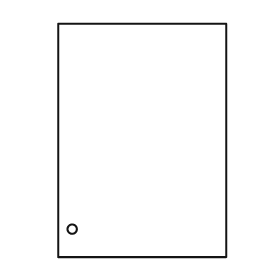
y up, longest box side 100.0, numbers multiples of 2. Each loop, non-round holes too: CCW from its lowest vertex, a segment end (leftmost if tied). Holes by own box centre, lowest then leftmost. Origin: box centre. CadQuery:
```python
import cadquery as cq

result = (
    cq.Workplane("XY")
    .moveTo(-36.0, -50.0)
    .lineTo(36.0, -50.0)
    .lineTo(36.0, 50.0)
    .lineTo(-36.0, 50.0)
    .close()
    .moveTo(-30.0, -38.0)
    .circle(2.0)
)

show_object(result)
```